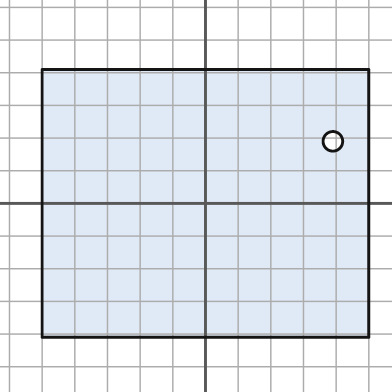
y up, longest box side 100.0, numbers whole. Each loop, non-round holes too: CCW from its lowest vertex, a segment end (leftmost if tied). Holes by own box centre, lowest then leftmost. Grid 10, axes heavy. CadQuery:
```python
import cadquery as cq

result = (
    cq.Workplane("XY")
    .moveTo(-50.0, -41.0)
    .lineTo(50.0, -41.0)
    .lineTo(50.0, 41.0)
    .lineTo(-50.0, 41.0)
    .close()
    .moveTo(39.0, 19.0)
    .circle(3.0)
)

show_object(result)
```